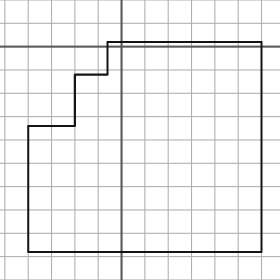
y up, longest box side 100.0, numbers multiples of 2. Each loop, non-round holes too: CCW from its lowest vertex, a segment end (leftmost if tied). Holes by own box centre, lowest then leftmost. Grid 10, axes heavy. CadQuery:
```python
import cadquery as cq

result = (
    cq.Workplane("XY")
    .moveTo(-40.0, -88.0)
    .lineTo(60.0, -88.0)
    .lineTo(60.0, 2.0)
    .lineTo(-6.0, 2.0)
    .lineTo(-6.0, -12.0)
    .lineTo(-20.0, -12.0)
    .lineTo(-20.0, -34.0)
    .lineTo(-40.0, -34.0)
    .close()
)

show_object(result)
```